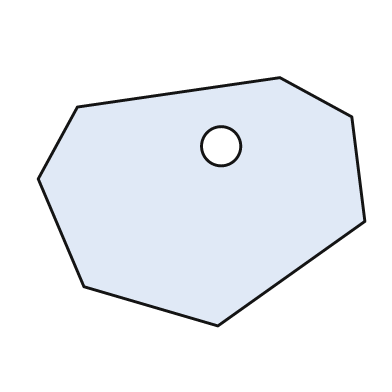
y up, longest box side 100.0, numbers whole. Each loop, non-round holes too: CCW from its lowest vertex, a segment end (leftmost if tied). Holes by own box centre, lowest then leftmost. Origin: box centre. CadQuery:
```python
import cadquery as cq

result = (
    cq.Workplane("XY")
    .moveTo(5.0, -38.0)
    .lineTo(50.0, -6.0)
    .lineTo(46.0, 26.0)
    .lineTo(24.0, 38.0)
    .lineTo(-38.0, 29.0)
    .lineTo(-50.0, 7.0)
    .lineTo(-36.0, -26.0)
    .close()
    .moveTo(6.0, 17.0)
    .circle(6.0)
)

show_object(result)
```